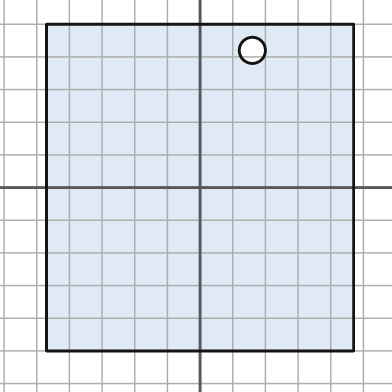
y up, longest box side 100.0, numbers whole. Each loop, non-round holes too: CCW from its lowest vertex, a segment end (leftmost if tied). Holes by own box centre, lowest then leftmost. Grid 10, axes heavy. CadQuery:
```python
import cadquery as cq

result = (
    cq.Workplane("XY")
    .moveTo(-47.0, -50.0)
    .lineTo(47.0, -50.0)
    .lineTo(47.0, 50.0)
    .lineTo(-47.0, 50.0)
    .close()
    .moveTo(16.0, 42.0)
    .circle(4.0)
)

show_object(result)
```